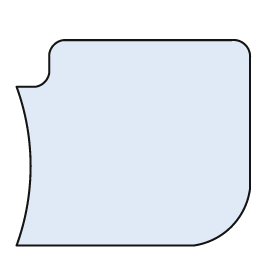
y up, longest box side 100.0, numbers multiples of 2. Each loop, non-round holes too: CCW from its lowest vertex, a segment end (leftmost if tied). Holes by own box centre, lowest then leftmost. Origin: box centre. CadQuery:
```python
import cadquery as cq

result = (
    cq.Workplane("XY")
    .moveTo(-50.0, -44.0)
    .lineTo(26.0, -44.0)
    .threePointArc((42.0, -36.0), (50.0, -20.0))
    .lineTo(50.0, 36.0)
    .threePointArc((48.0, 42.0), (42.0, 44.0))
    .lineTo(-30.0, 44.0)
    .threePointArc((-34.0, 42.0), (-36.0, 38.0))
    .lineTo(-36.0, 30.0)
    .threePointArc((-38.0, 26.0), (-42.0, 24.0))
    .lineTo(-50.0, 24.0)
    .threePointArc((-44.0, -10.0), (-50.0, -44.0))
    .close()
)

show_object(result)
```